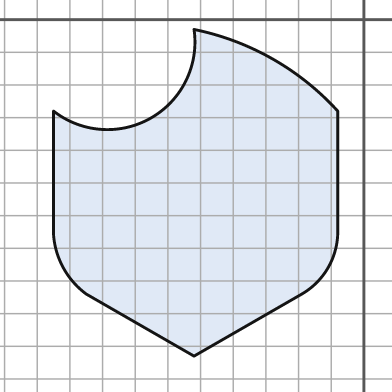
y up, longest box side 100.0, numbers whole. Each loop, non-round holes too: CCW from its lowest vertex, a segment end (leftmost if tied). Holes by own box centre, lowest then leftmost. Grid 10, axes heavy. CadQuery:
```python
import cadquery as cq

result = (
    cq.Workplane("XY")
    .moveTo(-52.0, -103.0)
    .lineTo(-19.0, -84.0)
    .threePointArc((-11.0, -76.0), (-8.0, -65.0))
    .lineTo(-8.0, -28.0)
    .threePointArc((-28.0, -12.0), (-52.0, -3.0))
    .threePointArc((-65.0, -30.0), (-95.0, -28.0))
    .lineTo(-95.0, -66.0)
    .threePointArc((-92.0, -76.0), (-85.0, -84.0))
    .close()
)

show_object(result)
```